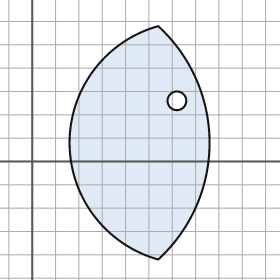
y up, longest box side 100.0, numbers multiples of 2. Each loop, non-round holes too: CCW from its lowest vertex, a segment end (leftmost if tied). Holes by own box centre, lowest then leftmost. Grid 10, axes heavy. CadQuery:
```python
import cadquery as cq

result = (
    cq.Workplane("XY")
    .moveTo(54.0, -42.0)
    .threePointArc((76.0, 8.0), (54.0, 58.0))
    .threePointArc((16.0, 8.0), (54.0, -42.0))
    .close()
    .moveTo(62.0, 26.0)
    .circle(4.0)
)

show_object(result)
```